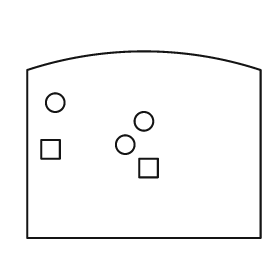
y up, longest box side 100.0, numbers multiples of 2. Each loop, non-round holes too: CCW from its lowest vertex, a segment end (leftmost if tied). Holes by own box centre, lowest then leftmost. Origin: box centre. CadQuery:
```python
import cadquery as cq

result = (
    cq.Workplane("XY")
    .moveTo(-50.0, -40.0)
    .lineTo(50.0, -40.0)
    .lineTo(50.0, 32.0)
    .threePointArc((0.0, 40.0), (-50.0, 32.0))
    .close()
    .moveTo(-2.0, -14.0)
    .lineTo(6.0, -14.0)
    .lineTo(6.0, -6.0)
    .lineTo(-2.0, -6.0)
    .close()
    .moveTo(-44.0, -6.0)
    .lineTo(-36.0, -6.0)
    .lineTo(-36.0, 2.0)
    .lineTo(-44.0, 2.0)
    .close()
    .moveTo(-8.0, 0.0)
    .circle(4.0)
    .moveTo(0.0, 10.0)
    .circle(4.0)
    .moveTo(-38.0, 18.0)
    .circle(4.0)
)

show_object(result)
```